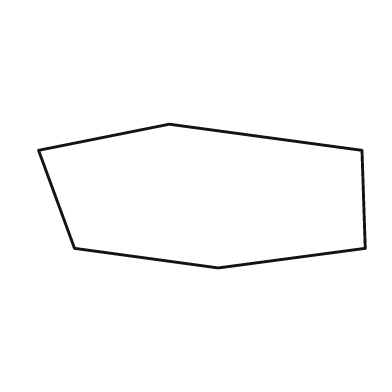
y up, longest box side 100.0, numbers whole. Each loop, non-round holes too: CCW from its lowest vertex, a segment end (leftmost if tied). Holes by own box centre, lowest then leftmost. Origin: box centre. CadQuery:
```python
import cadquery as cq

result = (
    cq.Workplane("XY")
    .moveTo(5.0, -22.0)
    .lineTo(50.0, -16.0)
    .lineTo(49.0, 14.0)
    .lineTo(-10.0, 22.0)
    .lineTo(-50.0, 14.0)
    .lineTo(-39.0, -16.0)
    .close()
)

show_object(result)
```